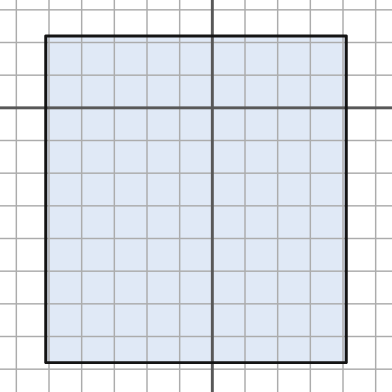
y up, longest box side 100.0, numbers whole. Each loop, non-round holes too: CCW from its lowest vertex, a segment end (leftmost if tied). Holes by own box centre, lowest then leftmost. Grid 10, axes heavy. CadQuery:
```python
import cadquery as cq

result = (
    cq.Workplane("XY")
    .moveTo(-51.0, -78.0)
    .lineTo(41.0, -78.0)
    .lineTo(41.0, 22.0)
    .lineTo(-51.0, 22.0)
    .close()
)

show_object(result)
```